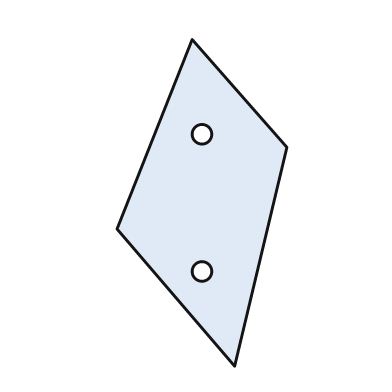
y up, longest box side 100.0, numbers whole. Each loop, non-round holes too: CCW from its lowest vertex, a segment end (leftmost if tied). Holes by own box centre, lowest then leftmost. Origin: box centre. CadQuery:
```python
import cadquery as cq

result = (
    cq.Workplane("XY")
    .moveTo(10.0, -50.0)
    .lineTo(26.0, 17.0)
    .lineTo(-3.0, 50.0)
    .lineTo(-26.0, -8.0)
    .close()
    .moveTo(0.0, -21.0)
    .circle(3.0)
    .moveTo(0.0, 21.0)
    .circle(3.0)
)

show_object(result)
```